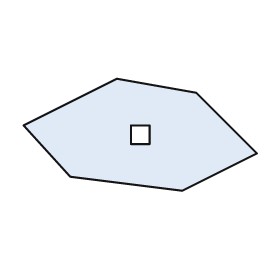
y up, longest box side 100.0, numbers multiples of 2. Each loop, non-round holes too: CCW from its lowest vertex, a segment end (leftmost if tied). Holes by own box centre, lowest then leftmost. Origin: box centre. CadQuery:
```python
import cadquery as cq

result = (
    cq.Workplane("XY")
    .moveTo(18.0, -24.0)
    .lineTo(50.0, -8.0)
    .lineTo(24.0, 18.0)
    .lineTo(-10.0, 24.0)
    .lineTo(-50.0, 4.0)
    .lineTo(-30.0, -18.0)
    .close()
    .moveTo(-4.0, -4.0)
    .lineTo(4.0, -4.0)
    .lineTo(4.0, 4.0)
    .lineTo(-4.0, 4.0)
    .close()
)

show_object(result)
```